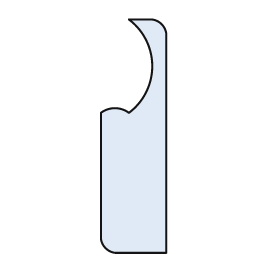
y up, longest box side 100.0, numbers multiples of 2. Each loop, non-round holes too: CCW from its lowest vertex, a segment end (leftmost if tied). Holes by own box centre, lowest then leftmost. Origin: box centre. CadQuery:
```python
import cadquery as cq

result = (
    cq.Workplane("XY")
    .moveTo(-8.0, -50.0)
    .lineTo(14.0, -50.0)
    .lineTo(14.0, 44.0)
    .threePointArc((12.0, 48.0), (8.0, 50.0))
    .lineTo(-2.0, 50.0)
    .threePointArc((8.0, 30.0), (-2.0, 10.0))
    .threePointArc((-8.0, 12.0), (-14.0, 10.0))
    .lineTo(-14.0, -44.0)
    .threePointArc((-12.0, -48.0), (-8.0, -50.0))
    .close()
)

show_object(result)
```